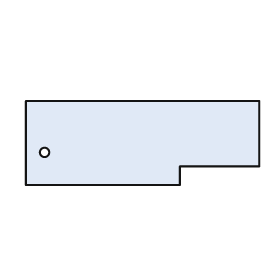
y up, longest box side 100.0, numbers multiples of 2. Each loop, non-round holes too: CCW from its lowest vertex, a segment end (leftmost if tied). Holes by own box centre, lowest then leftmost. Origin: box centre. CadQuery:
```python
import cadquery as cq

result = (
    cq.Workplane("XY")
    .moveTo(-50.0, -18.0)
    .lineTo(16.0, -18.0)
    .lineTo(16.0, -10.0)
    .lineTo(50.0, -10.0)
    .lineTo(50.0, 18.0)
    .lineTo(-50.0, 18.0)
    .close()
    .moveTo(-42.0, -4.0)
    .circle(2.0)
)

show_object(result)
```